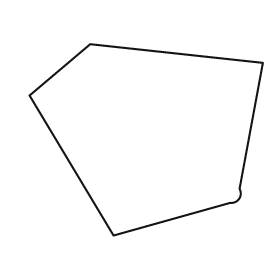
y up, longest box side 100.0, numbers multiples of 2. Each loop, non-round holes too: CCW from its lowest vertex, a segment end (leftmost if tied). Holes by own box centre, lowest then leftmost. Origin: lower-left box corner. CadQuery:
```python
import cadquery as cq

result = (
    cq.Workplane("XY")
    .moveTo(36.0, 0.0)
    .lineTo(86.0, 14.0)
    .threePointArc((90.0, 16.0), (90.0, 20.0))
    .lineTo(100.0, 74.0)
    .lineTo(26.0, 82.0)
    .lineTo(0.0, 60.0)
    .close()
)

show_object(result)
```